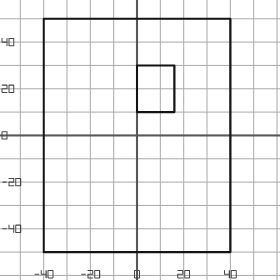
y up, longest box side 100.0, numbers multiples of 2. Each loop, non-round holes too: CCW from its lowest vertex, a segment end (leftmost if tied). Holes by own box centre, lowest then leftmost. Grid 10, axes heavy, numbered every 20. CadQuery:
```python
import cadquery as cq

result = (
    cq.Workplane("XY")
    .moveTo(-40.0, -50.0)
    .lineTo(40.0, -50.0)
    .lineTo(40.0, 50.0)
    .lineTo(-40.0, 50.0)
    .close()
    .moveTo(0.0, 10.0)
    .lineTo(16.0, 10.0)
    .lineTo(16.0, 30.0)
    .lineTo(0.0, 30.0)
    .close()
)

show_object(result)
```